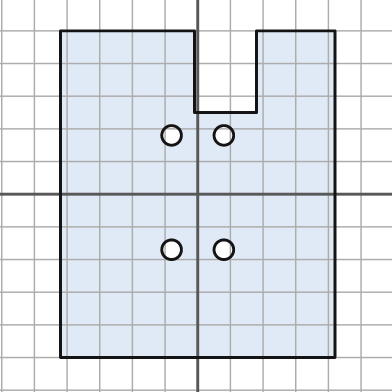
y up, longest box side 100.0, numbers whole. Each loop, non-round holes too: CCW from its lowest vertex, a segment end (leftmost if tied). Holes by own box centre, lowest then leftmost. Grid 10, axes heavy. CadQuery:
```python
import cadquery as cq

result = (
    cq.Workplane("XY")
    .moveTo(-42.0, -50.0)
    .lineTo(42.0, -50.0)
    .lineTo(42.0, 50.0)
    .lineTo(18.0, 50.0)
    .lineTo(18.0, 25.0)
    .lineTo(-1.0, 25.0)
    .lineTo(-1.0, 50.0)
    .lineTo(-42.0, 50.0)
    .close()
    .moveTo(-8.0, -17.0)
    .circle(3.0)
    .moveTo(8.0, -17.0)
    .circle(3.0)
    .moveTo(-8.0, 18.0)
    .circle(3.0)
    .moveTo(8.0, 18.0)
    .circle(3.0)
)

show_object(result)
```